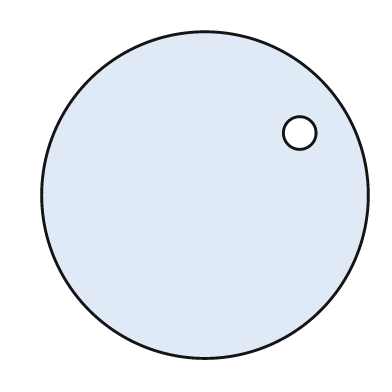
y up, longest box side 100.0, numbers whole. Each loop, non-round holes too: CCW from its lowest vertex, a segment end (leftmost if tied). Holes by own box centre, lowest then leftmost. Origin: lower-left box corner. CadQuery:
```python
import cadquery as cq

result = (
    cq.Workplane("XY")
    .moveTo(50.0, 50.0)
    .circle(50.0)
    .moveTo(79.0, 69.0)
    .circle(5.0)
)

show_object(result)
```